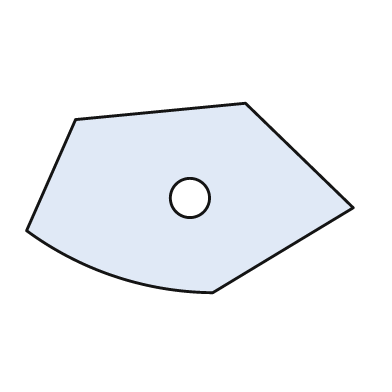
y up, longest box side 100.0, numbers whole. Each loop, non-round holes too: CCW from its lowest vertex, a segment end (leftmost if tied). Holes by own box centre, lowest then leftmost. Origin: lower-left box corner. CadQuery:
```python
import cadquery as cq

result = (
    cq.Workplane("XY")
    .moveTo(57.0, 0.0)
    .lineTo(100.0, 26.0)
    .lineTo(67.0, 58.0)
    .lineTo(15.0, 53.0)
    .lineTo(0.0, 19.0)
    .threePointArc((27.0, 5.0), (57.0, 0.0))
    .close()
    .moveTo(50.0, 29.0)
    .circle(6.0)
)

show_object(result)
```